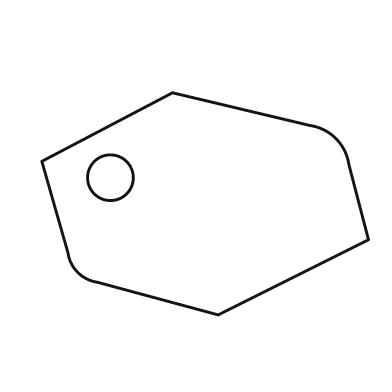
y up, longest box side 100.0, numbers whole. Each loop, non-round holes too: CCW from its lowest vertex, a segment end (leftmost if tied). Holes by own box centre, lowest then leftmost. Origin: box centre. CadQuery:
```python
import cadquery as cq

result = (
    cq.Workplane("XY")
    .moveTo(4.0, -34.0)
    .lineTo(50.0, -11.0)
    .lineTo(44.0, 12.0)
    .threePointArc((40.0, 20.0), (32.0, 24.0))
    .lineTo(-10.0, 34.0)
    .lineTo(-50.0, 13.0)
    .lineTo(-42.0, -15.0)
    .threePointArc((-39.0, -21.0), (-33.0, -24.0))
    .close()
    .moveTo(-29.0, 8.0)
    .circle(7.0)
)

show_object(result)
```